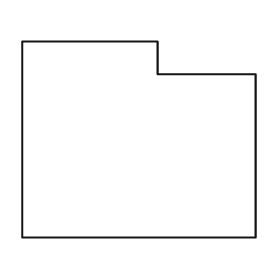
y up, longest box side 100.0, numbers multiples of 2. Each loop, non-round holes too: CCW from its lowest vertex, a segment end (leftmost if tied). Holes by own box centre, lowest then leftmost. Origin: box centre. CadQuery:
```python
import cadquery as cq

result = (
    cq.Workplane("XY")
    .moveTo(-50.0, -42.0)
    .lineTo(50.0, -42.0)
    .lineTo(50.0, 28.0)
    .lineTo(8.0, 28.0)
    .lineTo(8.0, 42.0)
    .lineTo(-50.0, 42.0)
    .close()
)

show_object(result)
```